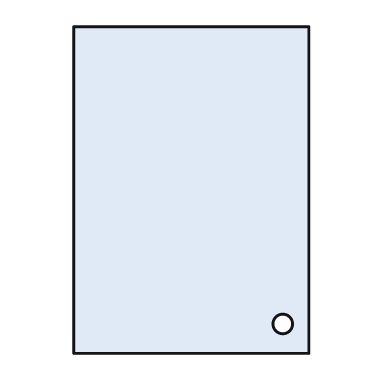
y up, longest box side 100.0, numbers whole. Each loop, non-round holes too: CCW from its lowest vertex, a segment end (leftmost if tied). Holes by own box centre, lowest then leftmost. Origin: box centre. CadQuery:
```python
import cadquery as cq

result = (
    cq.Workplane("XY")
    .moveTo(-36.0, -50.0)
    .lineTo(36.0, -50.0)
    .lineTo(36.0, 50.0)
    .lineTo(-36.0, 50.0)
    .close()
    .moveTo(28.0, -41.0)
    .circle(3.0)
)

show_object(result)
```